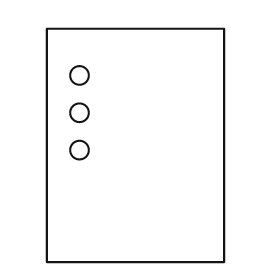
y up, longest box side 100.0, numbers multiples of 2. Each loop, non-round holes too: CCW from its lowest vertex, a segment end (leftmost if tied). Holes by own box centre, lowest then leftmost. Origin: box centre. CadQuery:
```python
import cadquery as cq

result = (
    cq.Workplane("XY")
    .moveTo(-38.0, -50.0)
    .lineTo(38.0, -50.0)
    .lineTo(38.0, 50.0)
    .lineTo(-38.0, 50.0)
    .close()
    .moveTo(-24.0, -2.0)
    .circle(4.0)
    .moveTo(-24.0, 14.0)
    .circle(4.0)
    .moveTo(-24.0, 30.0)
    .circle(4.0)
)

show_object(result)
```